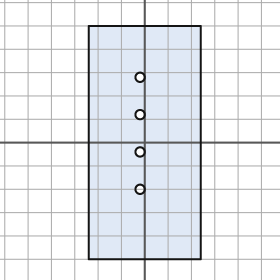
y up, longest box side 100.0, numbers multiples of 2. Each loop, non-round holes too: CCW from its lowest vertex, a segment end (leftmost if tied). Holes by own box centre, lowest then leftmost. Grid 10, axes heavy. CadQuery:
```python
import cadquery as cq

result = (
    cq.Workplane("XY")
    .moveTo(-24.0, -50.0)
    .lineTo(24.0, -50.0)
    .lineTo(24.0, 50.0)
    .lineTo(-24.0, 50.0)
    .close()
    .moveTo(-2.0, -20.0)
    .circle(2.0)
    .moveTo(-2.0, -4.0)
    .circle(2.0)
    .moveTo(-2.0, 12.0)
    .circle(2.0)
    .moveTo(-2.0, 28.0)
    .circle(2.0)
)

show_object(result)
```